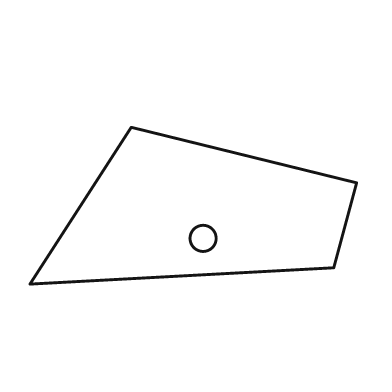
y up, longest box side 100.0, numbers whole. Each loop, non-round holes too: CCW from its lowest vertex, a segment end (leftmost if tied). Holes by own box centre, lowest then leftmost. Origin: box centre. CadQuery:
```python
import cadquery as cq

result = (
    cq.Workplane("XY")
    .moveTo(-50.0, -24.0)
    .lineTo(43.0, -19.0)
    .lineTo(50.0, 7.0)
    .lineTo(-19.0, 24.0)
    .close()
    .moveTo(3.0, -10.0)
    .circle(4.0)
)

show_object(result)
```